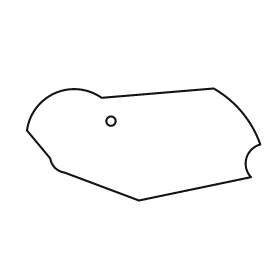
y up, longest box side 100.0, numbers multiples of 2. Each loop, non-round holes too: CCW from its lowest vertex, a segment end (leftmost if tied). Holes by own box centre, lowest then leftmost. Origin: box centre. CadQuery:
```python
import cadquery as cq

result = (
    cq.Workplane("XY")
    .moveTo(-2.0, -24.0)
    .lineTo(46.0, -14.0)
    .threePointArc((44.0, -6.0), (50.0, 0.0))
    .threePointArc((42.0, 14.0), (30.0, 24.0))
    .lineTo(-18.0, 20.0)
    .threePointArc((-38.0, 22.0), (-50.0, 6.0))
    .lineTo(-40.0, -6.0)
    .threePointArc((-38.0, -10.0), (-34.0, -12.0))
    .close()
    .moveTo(-14.0, 10.0)
    .circle(2.0)
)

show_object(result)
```